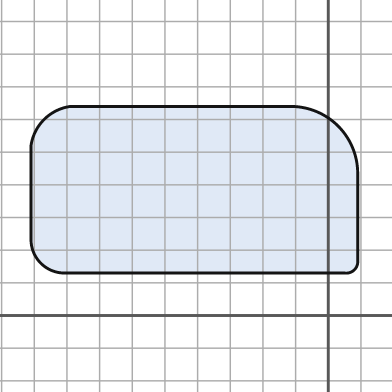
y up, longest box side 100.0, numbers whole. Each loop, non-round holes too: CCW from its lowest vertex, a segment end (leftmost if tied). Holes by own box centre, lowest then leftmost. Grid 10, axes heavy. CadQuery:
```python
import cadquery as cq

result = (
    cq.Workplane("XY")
    .moveTo(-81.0, 13.0)
    .lineTo(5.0, 13.0)
    .threePointArc((8.0, 14.0), (9.0, 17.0))
    .lineTo(9.0, 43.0)
    .threePointArc((3.0, 58.0), (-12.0, 64.0))
    .lineTo(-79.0, 64.0)
    .threePointArc((-87.0, 60.0), (-91.0, 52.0))
    .lineTo(-91.0, 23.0)
    .threePointArc((-88.0, 16.0), (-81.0, 13.0))
    .close()
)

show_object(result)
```